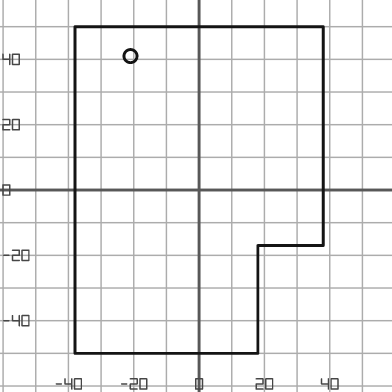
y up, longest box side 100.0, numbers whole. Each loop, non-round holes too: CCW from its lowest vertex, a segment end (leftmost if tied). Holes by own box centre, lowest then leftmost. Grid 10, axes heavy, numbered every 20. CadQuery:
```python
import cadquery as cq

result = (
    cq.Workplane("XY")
    .moveTo(-38.0, -50.0)
    .lineTo(18.0, -50.0)
    .lineTo(18.0, -17.0)
    .lineTo(38.0, -17.0)
    .lineTo(38.0, 50.0)
    .lineTo(-38.0, 50.0)
    .close()
    .moveTo(-21.0, 41.0)
    .circle(2.0)
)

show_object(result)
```